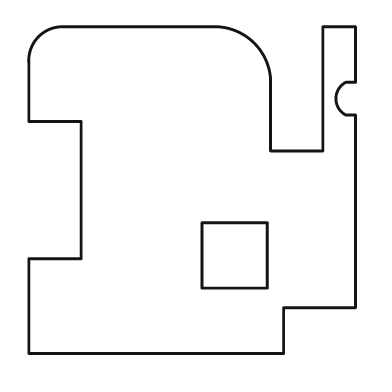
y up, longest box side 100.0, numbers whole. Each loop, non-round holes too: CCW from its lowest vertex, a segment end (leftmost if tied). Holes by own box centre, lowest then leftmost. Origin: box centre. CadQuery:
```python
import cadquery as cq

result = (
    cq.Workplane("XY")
    .moveTo(-50.0, -50.0)
    .lineTo(28.0, -50.0)
    .lineTo(28.0, -36.0)
    .lineTo(50.0, -36.0)
    .lineTo(50.0, 23.0)
    .lineTo(47.0, 23.0)
    .threePointArc((44.0, 28.0), (47.0, 33.0))
    .lineTo(50.0, 33.0)
    .lineTo(50.0, 50.0)
    .lineTo(40.0, 50.0)
    .lineTo(40.0, 12.0)
    .lineTo(24.0, 12.0)
    .lineTo(24.0, 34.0)
    .threePointArc((19.0, 45.0), (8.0, 50.0))
    .lineTo(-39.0, 50.0)
    .threePointArc((-47.0, 47.0), (-50.0, 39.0))
    .lineTo(-50.0, 21.0)
    .lineTo(-34.0, 21.0)
    .lineTo(-34.0, -21.0)
    .lineTo(-50.0, -21.0)
    .close()
    .moveTo(3.0, -30.0)
    .lineTo(23.0, -30.0)
    .lineTo(23.0, -10.0)
    .lineTo(3.0, -10.0)
    .close()
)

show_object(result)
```